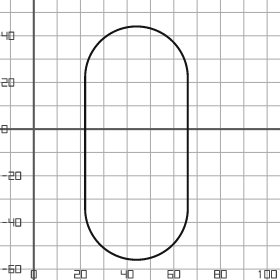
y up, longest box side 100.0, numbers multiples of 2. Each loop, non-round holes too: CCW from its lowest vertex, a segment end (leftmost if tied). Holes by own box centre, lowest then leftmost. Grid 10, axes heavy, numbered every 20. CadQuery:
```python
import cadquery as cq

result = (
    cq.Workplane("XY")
    .moveTo(22.0, -34.0)
    .threePointArc((44.0, -56.0), (66.0, -34.0))
    .lineTo(66.0, 22.0)
    .threePointArc((44.0, 44.0), (22.0, 22.0))
    .close()
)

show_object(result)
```